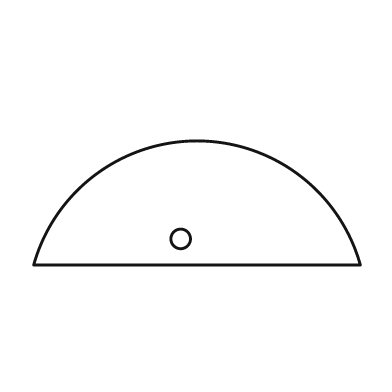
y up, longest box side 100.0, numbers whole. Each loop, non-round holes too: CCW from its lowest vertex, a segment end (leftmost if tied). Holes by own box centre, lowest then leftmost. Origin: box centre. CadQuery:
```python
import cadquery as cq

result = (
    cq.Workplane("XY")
    .moveTo(-50.0, -19.0)
    .lineTo(50.0, -19.0)
    .threePointArc((0.0, 19.0), (-50.0, -19.0))
    .close()
    .moveTo(-5.0, -11.0)
    .circle(3.0)
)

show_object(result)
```